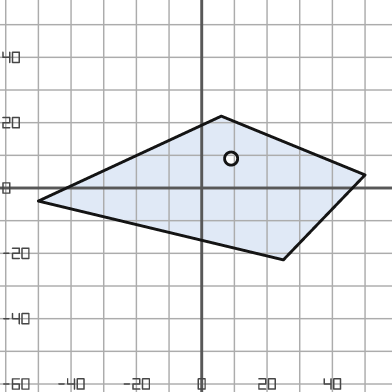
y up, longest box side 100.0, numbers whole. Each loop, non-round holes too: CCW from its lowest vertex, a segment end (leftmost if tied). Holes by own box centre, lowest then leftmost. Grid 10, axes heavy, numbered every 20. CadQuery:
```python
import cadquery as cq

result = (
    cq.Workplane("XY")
    .moveTo(25.0, -22.0)
    .lineTo(50.0, 4.0)
    .lineTo(6.0, 22.0)
    .lineTo(-50.0, -4.0)
    .close()
    .moveTo(9.0, 9.0)
    .circle(2.0)
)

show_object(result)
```